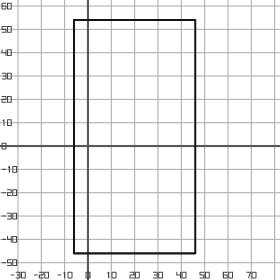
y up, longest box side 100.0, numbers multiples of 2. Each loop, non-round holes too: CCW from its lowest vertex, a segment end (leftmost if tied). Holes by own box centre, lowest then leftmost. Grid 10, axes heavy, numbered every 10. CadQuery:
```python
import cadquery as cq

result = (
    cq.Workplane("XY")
    .moveTo(-6.0, -46.0)
    .lineTo(46.0, -46.0)
    .lineTo(46.0, 54.0)
    .lineTo(-6.0, 54.0)
    .close()
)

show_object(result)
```